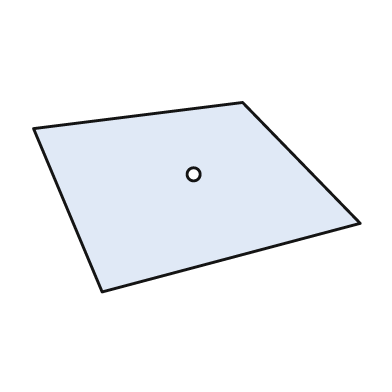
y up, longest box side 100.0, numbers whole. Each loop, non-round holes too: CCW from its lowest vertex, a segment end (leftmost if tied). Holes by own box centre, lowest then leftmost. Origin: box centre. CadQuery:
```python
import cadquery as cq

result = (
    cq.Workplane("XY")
    .moveTo(-29.0, -29.0)
    .lineTo(50.0, -8.0)
    .lineTo(14.0, 29.0)
    .lineTo(-50.0, 21.0)
    .close()
    .moveTo(-1.0, 7.0)
    .circle(2.0)
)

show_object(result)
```